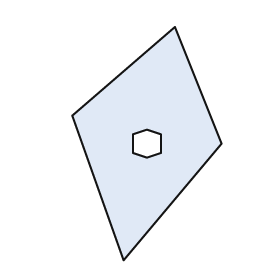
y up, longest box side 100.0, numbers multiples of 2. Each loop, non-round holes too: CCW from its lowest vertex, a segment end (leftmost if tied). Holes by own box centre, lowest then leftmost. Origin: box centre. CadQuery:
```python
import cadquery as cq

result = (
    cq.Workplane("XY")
    .moveTo(-10.0, -50.0)
    .lineTo(32.0, 0.0)
    .lineTo(12.0, 50.0)
    .lineTo(-32.0, 12.0)
    .close()
    .moveTo(0.0, -6.0)
    .lineTo(6.0, -4.0)
    .lineTo(6.0, 4.0)
    .lineTo(0.0, 6.0)
    .lineTo(-6.0, 4.0)
    .lineTo(-6.0, -4.0)
    .close()
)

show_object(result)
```